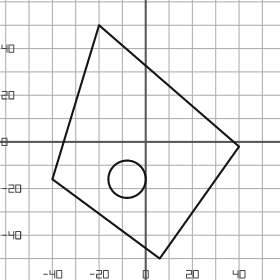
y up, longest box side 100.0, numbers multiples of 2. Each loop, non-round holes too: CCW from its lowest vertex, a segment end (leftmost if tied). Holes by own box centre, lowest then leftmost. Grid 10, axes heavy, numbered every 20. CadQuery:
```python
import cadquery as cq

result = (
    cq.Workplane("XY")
    .moveTo(6.0, -50.0)
    .lineTo(40.0, -2.0)
    .lineTo(-20.0, 50.0)
    .lineTo(-40.0, -16.0)
    .close()
    .moveTo(-8.0, -16.0)
    .circle(8.0)
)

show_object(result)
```